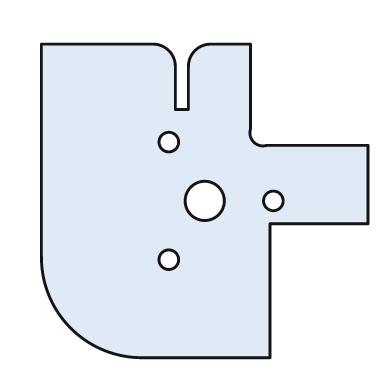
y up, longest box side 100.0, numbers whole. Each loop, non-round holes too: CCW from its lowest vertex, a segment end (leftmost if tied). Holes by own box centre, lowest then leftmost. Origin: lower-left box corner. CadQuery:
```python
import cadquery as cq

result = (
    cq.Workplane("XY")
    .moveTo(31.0, 0.0)
    .lineTo(70.0, 0.0)
    .lineTo(70.0, 41.0)
    .lineTo(100.0, 41.0)
    .lineTo(100.0, 65.0)
    .lineTo(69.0, 65.0)
    .threePointArc((65.0, 66.0), (64.0, 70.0))
    .lineTo(64.0, 96.0)
    .lineTo(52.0, 96.0)
    .threePointArc((47.0, 94.0), (45.0, 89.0))
    .lineTo(45.0, 76.0)
    .lineTo(41.0, 76.0)
    .lineTo(41.0, 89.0)
    .threePointArc((39.0, 94.0), (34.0, 96.0))
    .lineTo(0.0, 96.0)
    .lineTo(0.0, 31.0)
    .threePointArc((9.0, 9.0), (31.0, 0.0))
    .close()
    .moveTo(39.0, 30.0)
    .circle(3.0)
    .moveTo(50.0, 48.0)
    .circle(6.0)
    .moveTo(71.0, 48.0)
    .circle(3.0)
    .moveTo(39.0, 66.0)
    .circle(3.0)
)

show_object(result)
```